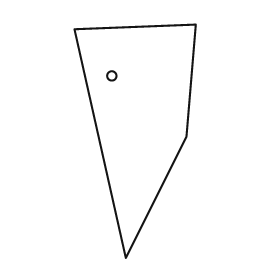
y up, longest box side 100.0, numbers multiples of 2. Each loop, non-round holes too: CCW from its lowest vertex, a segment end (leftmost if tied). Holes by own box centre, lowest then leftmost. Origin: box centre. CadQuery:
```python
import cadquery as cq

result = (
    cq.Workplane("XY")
    .moveTo(-4.0, -50.0)
    .lineTo(22.0, 2.0)
    .lineTo(26.0, 50.0)
    .lineTo(-26.0, 48.0)
    .close()
    .moveTo(-10.0, 28.0)
    .circle(2.0)
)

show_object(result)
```